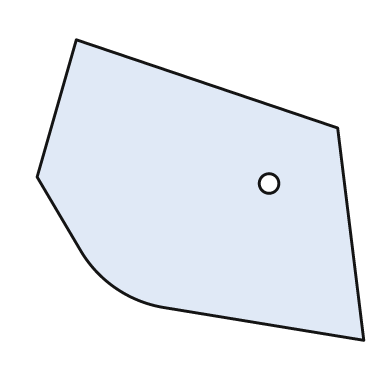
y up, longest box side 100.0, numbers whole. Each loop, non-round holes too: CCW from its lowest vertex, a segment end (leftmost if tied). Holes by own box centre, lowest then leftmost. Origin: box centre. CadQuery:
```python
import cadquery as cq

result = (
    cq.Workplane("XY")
    .moveTo(50.0, -46.0)
    .lineTo(42.0, 19.0)
    .lineTo(-38.0, 46.0)
    .lineTo(-50.0, 4.0)
    .lineTo(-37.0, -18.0)
    .threePointArc((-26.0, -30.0), (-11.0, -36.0))
    .close()
    .moveTo(21.0, 2.0)
    .circle(3.0)
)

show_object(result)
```